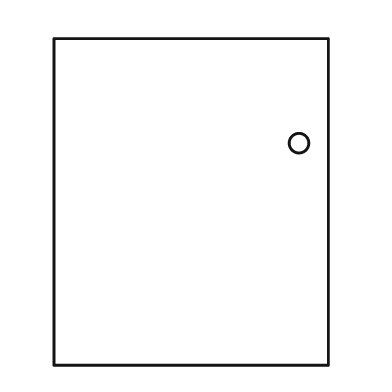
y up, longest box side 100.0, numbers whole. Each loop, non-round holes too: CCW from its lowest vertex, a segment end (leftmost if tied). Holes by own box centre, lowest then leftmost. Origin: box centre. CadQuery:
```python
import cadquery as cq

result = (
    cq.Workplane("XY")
    .moveTo(-42.0, -50.0)
    .lineTo(42.0, -50.0)
    .lineTo(42.0, 50.0)
    .lineTo(-42.0, 50.0)
    .close()
    .moveTo(33.0, 18.0)
    .circle(3.0)
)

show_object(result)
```